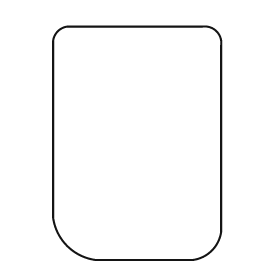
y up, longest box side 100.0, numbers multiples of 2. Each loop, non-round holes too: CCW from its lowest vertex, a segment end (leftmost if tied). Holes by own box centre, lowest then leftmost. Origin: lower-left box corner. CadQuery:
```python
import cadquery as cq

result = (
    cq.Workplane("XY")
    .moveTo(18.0, 0.0)
    .lineTo(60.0, 0.0)
    .threePointArc((68.0, 4.0), (72.0, 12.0))
    .lineTo(72.0, 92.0)
    .threePointArc((70.0, 98.0), (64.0, 100.0))
    .lineTo(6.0, 100.0)
    .threePointArc((2.0, 98.0), (0.0, 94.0))
    .lineTo(0.0, 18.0)
    .threePointArc((6.0, 6.0), (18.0, 0.0))
    .close()
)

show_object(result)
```